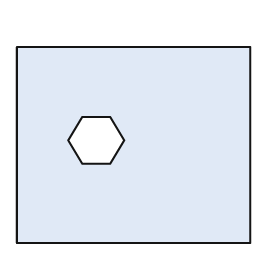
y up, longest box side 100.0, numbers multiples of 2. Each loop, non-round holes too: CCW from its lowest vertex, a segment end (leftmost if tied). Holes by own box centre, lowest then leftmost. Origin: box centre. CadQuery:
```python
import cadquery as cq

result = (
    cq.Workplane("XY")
    .moveTo(-50.0, -42.0)
    .lineTo(50.0, -42.0)
    .lineTo(50.0, 42.0)
    .lineTo(-50.0, 42.0)
    .close()
    .moveTo(-22.0, -8.0)
    .lineTo(-10.0, -8.0)
    .lineTo(-4.0, 2.0)
    .lineTo(-10.0, 12.0)
    .lineTo(-22.0, 12.0)
    .lineTo(-28.0, 2.0)
    .close()
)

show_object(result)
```